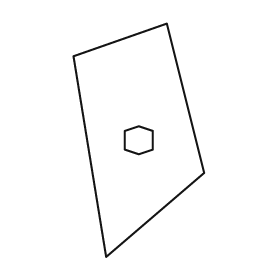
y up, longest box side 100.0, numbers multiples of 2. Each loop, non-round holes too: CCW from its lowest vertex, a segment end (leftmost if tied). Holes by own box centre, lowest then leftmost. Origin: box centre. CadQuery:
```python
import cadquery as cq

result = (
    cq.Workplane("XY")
    .moveTo(-14.0, -50.0)
    .lineTo(28.0, -14.0)
    .lineTo(12.0, 50.0)
    .lineTo(-28.0, 36.0)
    .close()
    .moveTo(0.0, -6.0)
    .lineTo(6.0, -4.0)
    .lineTo(6.0, 4.0)
    .lineTo(0.0, 6.0)
    .lineTo(-6.0, 4.0)
    .lineTo(-6.0, -4.0)
    .close()
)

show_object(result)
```